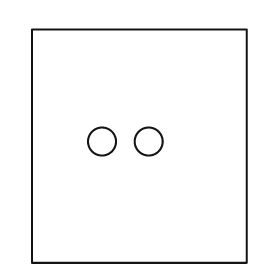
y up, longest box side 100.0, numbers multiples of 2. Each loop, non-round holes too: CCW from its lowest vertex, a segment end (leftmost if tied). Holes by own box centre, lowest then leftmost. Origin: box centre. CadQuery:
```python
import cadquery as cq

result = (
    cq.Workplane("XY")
    .moveTo(-46.0, -50.0)
    .lineTo(46.0, -50.0)
    .lineTo(46.0, 50.0)
    .lineTo(-46.0, 50.0)
    .close()
    .moveTo(-16.0, 2.0)
    .circle(6.0)
    .moveTo(4.0, 2.0)
    .circle(6.0)
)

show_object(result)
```